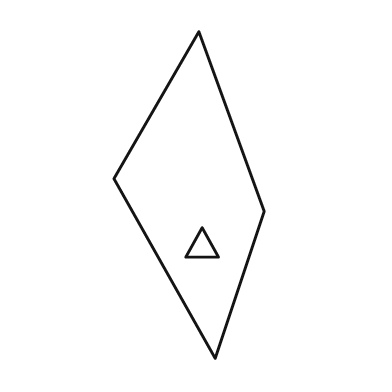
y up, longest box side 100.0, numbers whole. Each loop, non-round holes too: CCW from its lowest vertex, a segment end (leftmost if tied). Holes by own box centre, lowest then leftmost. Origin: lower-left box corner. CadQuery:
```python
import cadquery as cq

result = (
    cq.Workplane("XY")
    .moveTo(31.0, 0.0)
    .lineTo(46.0, 45.0)
    .lineTo(26.0, 100.0)
    .lineTo(0.0, 55.0)
    .close()
    .moveTo(22.0, 31.0)
    .lineTo(32.0, 31.0)
    .lineTo(27.0, 40.0)
    .close()
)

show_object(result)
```